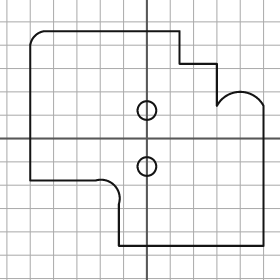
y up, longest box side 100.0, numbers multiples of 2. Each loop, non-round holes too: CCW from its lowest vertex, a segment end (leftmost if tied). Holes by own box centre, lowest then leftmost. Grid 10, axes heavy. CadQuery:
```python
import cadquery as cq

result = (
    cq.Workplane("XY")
    .moveTo(-12.0, -46.0)
    .lineTo(50.0, -46.0)
    .lineTo(50.0, 14.0)
    .threePointArc((40.0, 20.0), (30.0, 14.0))
    .lineTo(30.0, 32.0)
    .lineTo(14.0, 32.0)
    .lineTo(14.0, 46.0)
    .lineTo(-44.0, 46.0)
    .threePointArc((-48.0, 44.0), (-50.0, 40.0))
    .lineTo(-50.0, -18.0)
    .lineTo(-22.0, -18.0)
    .threePointArc((-14.0, -20.0), (-12.0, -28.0))
    .close()
    .moveTo(0.0, -12.0)
    .circle(4.0)
    .moveTo(0.0, 12.0)
    .circle(4.0)
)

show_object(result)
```